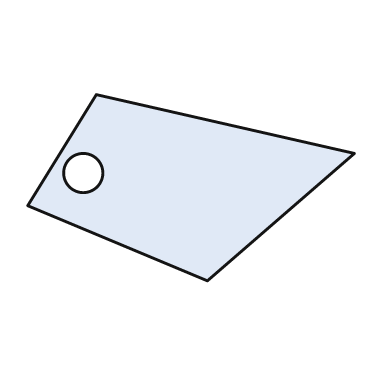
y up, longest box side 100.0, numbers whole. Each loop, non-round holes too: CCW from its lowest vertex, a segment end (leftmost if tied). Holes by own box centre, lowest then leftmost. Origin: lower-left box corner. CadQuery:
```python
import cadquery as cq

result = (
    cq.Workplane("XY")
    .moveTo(55.0, 0.0)
    .lineTo(100.0, 39.0)
    .lineTo(21.0, 57.0)
    .lineTo(0.0, 23.0)
    .close()
    .moveTo(17.0, 33.0)
    .circle(6.0)
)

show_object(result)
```